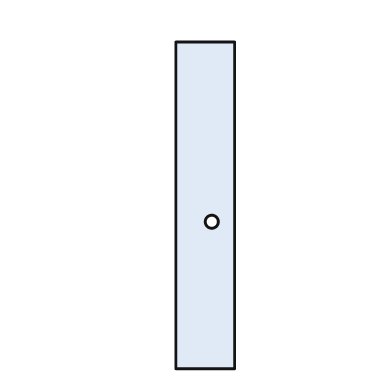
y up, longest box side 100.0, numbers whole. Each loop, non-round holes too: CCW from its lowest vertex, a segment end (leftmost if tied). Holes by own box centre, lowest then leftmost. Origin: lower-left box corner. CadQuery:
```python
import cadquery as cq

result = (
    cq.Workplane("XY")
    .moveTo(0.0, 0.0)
    .lineTo(18.0, 0.0)
    .lineTo(18.0, 100.0)
    .lineTo(0.0, 100.0)
    .close()
    .moveTo(11.0, 45.0)
    .circle(2.0)
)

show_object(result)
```